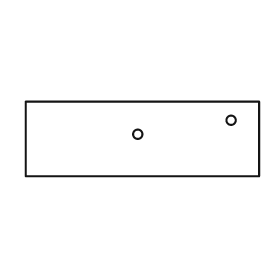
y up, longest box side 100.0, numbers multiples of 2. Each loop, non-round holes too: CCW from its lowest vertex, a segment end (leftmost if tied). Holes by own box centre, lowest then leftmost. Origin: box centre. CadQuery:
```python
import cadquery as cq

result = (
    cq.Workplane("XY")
    .moveTo(-50.0, -16.0)
    .lineTo(50.0, -16.0)
    .lineTo(50.0, 16.0)
    .lineTo(-50.0, 16.0)
    .close()
    .moveTo(-2.0, 2.0)
    .circle(2.0)
    .moveTo(38.0, 8.0)
    .circle(2.0)
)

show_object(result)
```